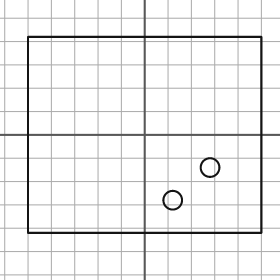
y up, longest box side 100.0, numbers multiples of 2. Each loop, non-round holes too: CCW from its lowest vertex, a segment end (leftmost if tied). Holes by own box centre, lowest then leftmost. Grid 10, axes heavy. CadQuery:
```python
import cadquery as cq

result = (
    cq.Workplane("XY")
    .moveTo(-50.0, -42.0)
    .lineTo(50.0, -42.0)
    .lineTo(50.0, 42.0)
    .lineTo(-50.0, 42.0)
    .close()
    .moveTo(12.0, -28.0)
    .circle(4.0)
    .moveTo(28.0, -14.0)
    .circle(4.0)
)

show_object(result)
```